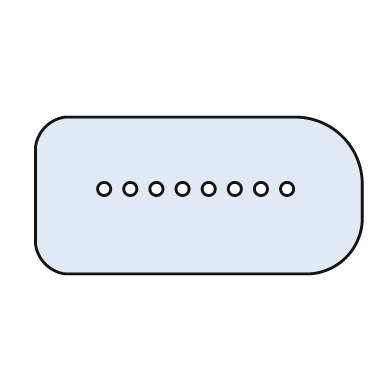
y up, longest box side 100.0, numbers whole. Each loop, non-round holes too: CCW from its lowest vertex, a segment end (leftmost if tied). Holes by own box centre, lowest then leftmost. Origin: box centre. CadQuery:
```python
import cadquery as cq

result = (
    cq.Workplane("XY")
    .moveTo(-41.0, -24.0)
    .lineTo(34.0, -24.0)
    .threePointArc((45.0, -19.0), (50.0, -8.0))
    .lineTo(50.0, 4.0)
    .threePointArc((44.0, 18.0), (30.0, 24.0))
    .lineTo(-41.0, 24.0)
    .threePointArc((-47.0, 21.0), (-50.0, 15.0))
    .lineTo(-50.0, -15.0)
    .threePointArc((-47.0, -21.0), (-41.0, -24.0))
    .close()
    .moveTo(-29.0, 2.0)
    .circle(2.0)
    .moveTo(-21.0, 2.0)
    .circle(2.0)
    .moveTo(-13.0, 2.0)
    .circle(2.0)
    .moveTo(-5.0, 2.0)
    .circle(2.0)
    .moveTo(3.0, 2.0)
    .circle(2.0)
    .moveTo(11.0, 2.0)
    .circle(2.0)
    .moveTo(19.0, 2.0)
    .circle(2.0)
    .moveTo(27.0, 2.0)
    .circle(2.0)
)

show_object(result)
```